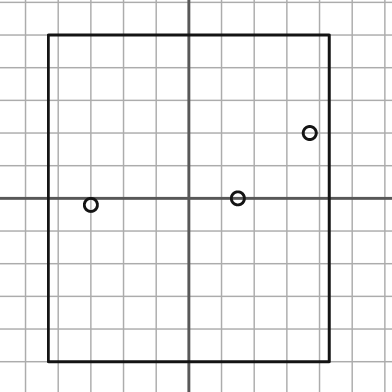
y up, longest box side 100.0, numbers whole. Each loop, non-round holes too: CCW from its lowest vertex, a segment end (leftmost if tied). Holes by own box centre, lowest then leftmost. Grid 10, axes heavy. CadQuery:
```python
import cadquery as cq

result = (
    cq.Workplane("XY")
    .moveTo(-43.0, -50.0)
    .lineTo(43.0, -50.0)
    .lineTo(43.0, 50.0)
    .lineTo(-43.0, 50.0)
    .close()
    .moveTo(-30.0, -2.0)
    .circle(2.0)
    .moveTo(15.0, 0.0)
    .circle(2.0)
    .moveTo(37.0, 20.0)
    .circle(2.0)
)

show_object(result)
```